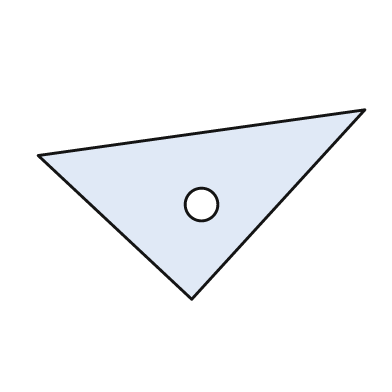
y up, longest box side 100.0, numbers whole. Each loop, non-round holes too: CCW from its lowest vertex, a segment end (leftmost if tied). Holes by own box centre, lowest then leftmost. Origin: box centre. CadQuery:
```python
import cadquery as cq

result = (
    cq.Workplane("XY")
    .moveTo(-3.0, -29.0)
    .lineTo(50.0, 29.0)
    .lineTo(-50.0, 15.0)
    .close()
    .moveTo(0.0, 0.0)
    .circle(5.0)
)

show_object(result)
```